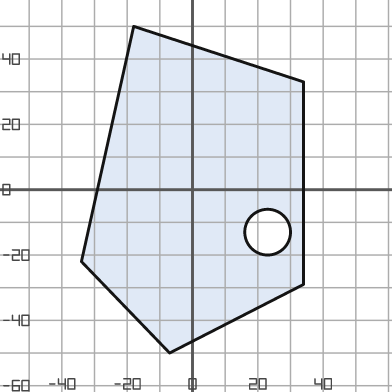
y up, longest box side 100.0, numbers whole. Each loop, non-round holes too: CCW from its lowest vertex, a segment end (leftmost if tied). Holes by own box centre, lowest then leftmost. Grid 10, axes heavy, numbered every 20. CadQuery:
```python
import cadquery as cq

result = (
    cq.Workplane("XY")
    .moveTo(-7.0, -50.0)
    .lineTo(34.0, -29.0)
    .lineTo(34.0, 33.0)
    .lineTo(-18.0, 50.0)
    .lineTo(-34.0, -22.0)
    .close()
    .moveTo(23.0, -13.0)
    .circle(7.0)
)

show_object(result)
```